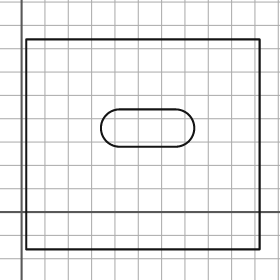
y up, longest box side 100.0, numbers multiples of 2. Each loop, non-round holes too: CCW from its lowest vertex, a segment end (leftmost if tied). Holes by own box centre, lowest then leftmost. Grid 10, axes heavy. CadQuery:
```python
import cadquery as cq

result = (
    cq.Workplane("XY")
    .moveTo(2.0, -16.0)
    .lineTo(102.0, -16.0)
    .lineTo(102.0, 74.0)
    .lineTo(2.0, 74.0)
    .close()
    .moveTo(42.0, 28.0)
    .lineTo(66.0, 28.0)
    .threePointArc((74.0, 36.0), (66.0, 44.0))
    .lineTo(42.0, 44.0)
    .threePointArc((34.0, 36.0), (42.0, 28.0))
    .close()
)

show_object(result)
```